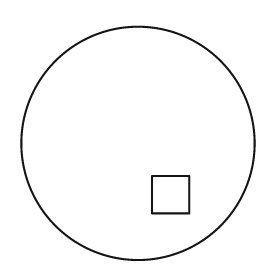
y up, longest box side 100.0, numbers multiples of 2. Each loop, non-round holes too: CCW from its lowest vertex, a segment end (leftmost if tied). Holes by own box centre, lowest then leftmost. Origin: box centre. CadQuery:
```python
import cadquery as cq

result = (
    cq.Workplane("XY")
    .moveTo(0.0, 0.0)
    .circle(50.0)
    .moveTo(6.0, -30.0)
    .lineTo(22.0, -30.0)
    .lineTo(22.0, -14.0)
    .lineTo(6.0, -14.0)
    .close()
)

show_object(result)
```